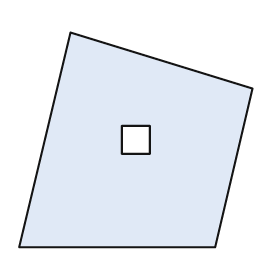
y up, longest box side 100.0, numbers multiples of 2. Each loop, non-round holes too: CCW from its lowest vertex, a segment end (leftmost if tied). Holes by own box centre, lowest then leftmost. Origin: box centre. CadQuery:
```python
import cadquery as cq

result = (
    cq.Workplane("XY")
    .moveTo(-50.0, -46.0)
    .lineTo(34.0, -46.0)
    .lineTo(50.0, 22.0)
    .lineTo(-28.0, 46.0)
    .close()
    .moveTo(-6.0, -6.0)
    .lineTo(6.0, -6.0)
    .lineTo(6.0, 6.0)
    .lineTo(-6.0, 6.0)
    .close()
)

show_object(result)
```